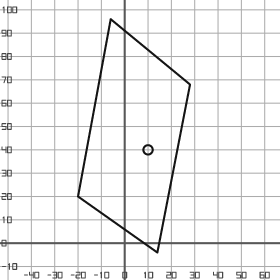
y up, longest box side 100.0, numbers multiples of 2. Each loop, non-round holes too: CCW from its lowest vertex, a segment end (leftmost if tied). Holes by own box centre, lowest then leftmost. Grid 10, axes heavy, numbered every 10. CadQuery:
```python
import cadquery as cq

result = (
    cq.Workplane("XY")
    .moveTo(14.0, -4.0)
    .lineTo(28.0, 68.0)
    .lineTo(-6.0, 96.0)
    .lineTo(-20.0, 20.0)
    .close()
    .moveTo(10.0, 40.0)
    .circle(2.0)
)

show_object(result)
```